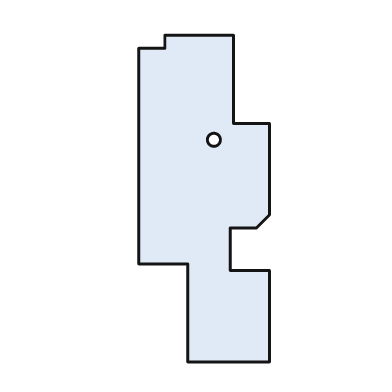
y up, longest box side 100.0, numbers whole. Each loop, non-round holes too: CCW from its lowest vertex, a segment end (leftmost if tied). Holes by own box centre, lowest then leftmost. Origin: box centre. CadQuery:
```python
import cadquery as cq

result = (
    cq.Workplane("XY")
    .moveTo(-5.0, -50.0)
    .lineTo(20.0, -50.0)
    .lineTo(20.0, -22.0)
    .lineTo(8.0, -22.0)
    .lineTo(8.0, -9.0)
    .lineTo(16.0, -9.0)
    .lineTo(20.0, -5.0)
    .lineTo(20.0, 23.0)
    .lineTo(9.0, 23.0)
    .lineTo(9.0, 50.0)
    .lineTo(-12.0, 50.0)
    .lineTo(-12.0, 46.0)
    .lineTo(-20.0, 46.0)
    .lineTo(-20.0, -20.0)
    .lineTo(-5.0, -20.0)
    .close()
    .moveTo(3.0, 18.0)
    .circle(2.0)
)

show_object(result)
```